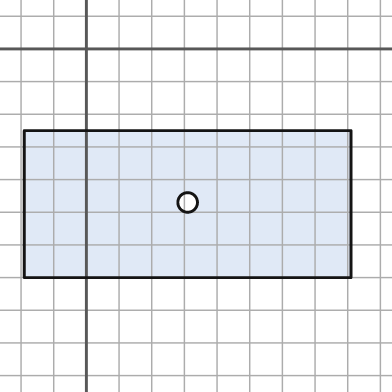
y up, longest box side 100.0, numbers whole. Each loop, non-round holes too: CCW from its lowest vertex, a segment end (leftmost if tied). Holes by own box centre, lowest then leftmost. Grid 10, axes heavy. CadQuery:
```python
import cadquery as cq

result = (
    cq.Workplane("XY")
    .moveTo(-19.0, -70.0)
    .lineTo(81.0, -70.0)
    .lineTo(81.0, -25.0)
    .lineTo(-19.0, -25.0)
    .close()
    .moveTo(31.0, -47.0)
    .circle(3.0)
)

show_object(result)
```